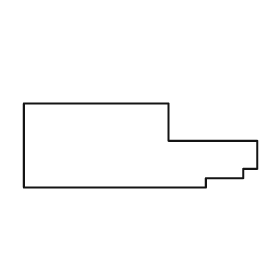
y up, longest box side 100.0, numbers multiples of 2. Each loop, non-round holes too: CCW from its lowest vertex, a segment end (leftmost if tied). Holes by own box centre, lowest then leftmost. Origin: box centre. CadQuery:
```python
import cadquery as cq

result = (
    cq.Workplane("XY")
    .moveTo(-50.0, -18.0)
    .lineTo(28.0, -18.0)
    .lineTo(28.0, -14.0)
    .lineTo(44.0, -14.0)
    .lineTo(44.0, -10.0)
    .lineTo(50.0, -10.0)
    .lineTo(50.0, 2.0)
    .lineTo(12.0, 2.0)
    .lineTo(12.0, 18.0)
    .lineTo(-50.0, 18.0)
    .close()
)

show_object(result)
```